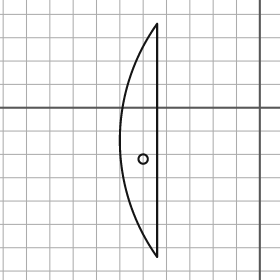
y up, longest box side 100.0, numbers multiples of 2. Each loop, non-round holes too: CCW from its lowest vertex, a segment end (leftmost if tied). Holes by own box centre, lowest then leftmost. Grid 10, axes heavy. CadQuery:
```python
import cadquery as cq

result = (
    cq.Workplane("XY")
    .moveTo(-44.0, -64.0)
    .lineTo(-44.0, 36.0)
    .threePointArc((-60.0, -14.0), (-44.0, -64.0))
    .close()
    .moveTo(-50.0, -22.0)
    .circle(2.0)
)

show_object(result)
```